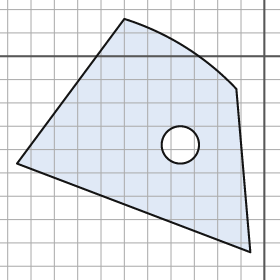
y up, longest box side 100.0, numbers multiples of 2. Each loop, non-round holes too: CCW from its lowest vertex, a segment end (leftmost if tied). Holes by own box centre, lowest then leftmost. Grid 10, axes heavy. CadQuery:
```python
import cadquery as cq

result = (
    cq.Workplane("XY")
    .moveTo(-6.0, -84.0)
    .lineTo(-12.0, -14.0)
    .threePointArc((-34.0, 4.0), (-60.0, 16.0))
    .lineTo(-106.0, -46.0)
    .close()
    .moveTo(-36.0, -38.0)
    .circle(8.0)
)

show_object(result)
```